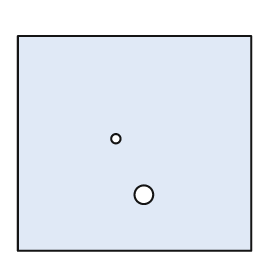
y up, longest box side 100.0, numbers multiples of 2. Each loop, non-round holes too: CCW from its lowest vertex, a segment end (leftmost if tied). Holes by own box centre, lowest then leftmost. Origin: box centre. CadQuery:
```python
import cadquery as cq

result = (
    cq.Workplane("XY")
    .moveTo(-50.0, -46.0)
    .lineTo(50.0, -46.0)
    .lineTo(50.0, 46.0)
    .lineTo(-50.0, 46.0)
    .close()
    .moveTo(4.0, -22.0)
    .circle(4.0)
    .moveTo(-8.0, 2.0)
    .circle(2.0)
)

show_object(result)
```